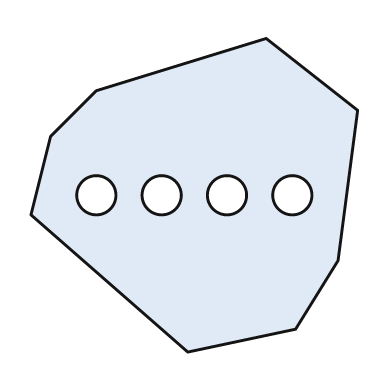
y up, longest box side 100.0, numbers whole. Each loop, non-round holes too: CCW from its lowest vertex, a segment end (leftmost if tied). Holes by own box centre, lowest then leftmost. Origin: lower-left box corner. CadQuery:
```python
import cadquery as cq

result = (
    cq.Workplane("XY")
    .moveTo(48.0, 0.0)
    .lineTo(81.0, 7.0)
    .lineTo(94.0, 28.0)
    .lineTo(100.0, 74.0)
    .lineTo(72.0, 96.0)
    .lineTo(20.0, 80.0)
    .lineTo(6.0, 66.0)
    .lineTo(0.0, 42.0)
    .close()
    .moveTo(20.0, 48.0)
    .circle(6.0)
    .moveTo(40.0, 48.0)
    .circle(6.0)
    .moveTo(60.0, 48.0)
    .circle(6.0)
    .moveTo(80.0, 48.0)
    .circle(6.0)
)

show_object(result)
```